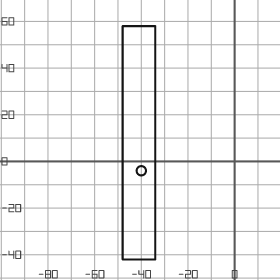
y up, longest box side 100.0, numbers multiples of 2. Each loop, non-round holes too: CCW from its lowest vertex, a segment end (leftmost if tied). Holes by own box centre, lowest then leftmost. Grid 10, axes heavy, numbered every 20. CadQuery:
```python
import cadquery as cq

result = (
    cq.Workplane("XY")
    .moveTo(-48.0, -42.0)
    .lineTo(-34.0, -42.0)
    .lineTo(-34.0, 58.0)
    .lineTo(-48.0, 58.0)
    .close()
    .moveTo(-40.0, -4.0)
    .circle(2.0)
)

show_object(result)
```